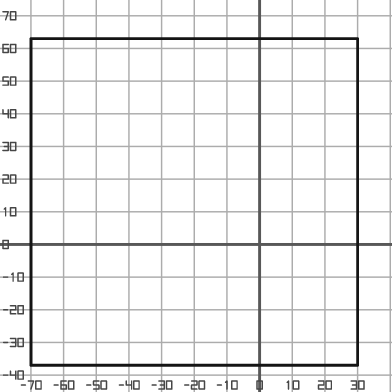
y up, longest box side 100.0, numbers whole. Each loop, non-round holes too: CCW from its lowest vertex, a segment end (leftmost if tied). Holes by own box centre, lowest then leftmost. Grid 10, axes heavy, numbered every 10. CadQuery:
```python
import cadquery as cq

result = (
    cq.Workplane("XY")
    .moveTo(-70.0, -37.0)
    .lineTo(30.0, -37.0)
    .lineTo(30.0, 63.0)
    .lineTo(-70.0, 63.0)
    .close()
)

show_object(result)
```